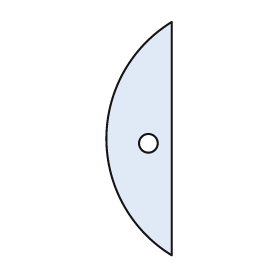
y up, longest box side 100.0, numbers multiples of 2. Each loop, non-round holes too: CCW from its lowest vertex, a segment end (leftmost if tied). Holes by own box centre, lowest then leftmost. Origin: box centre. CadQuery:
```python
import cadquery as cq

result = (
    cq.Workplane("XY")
    .moveTo(14.0, -50.0)
    .lineTo(14.0, 50.0)
    .threePointArc((-14.0, 0.0), (14.0, -50.0))
    .close()
    .moveTo(4.0, -2.0)
    .circle(4.0)
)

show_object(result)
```